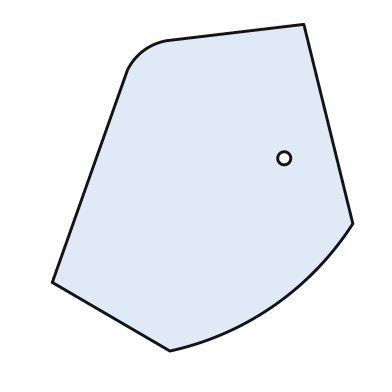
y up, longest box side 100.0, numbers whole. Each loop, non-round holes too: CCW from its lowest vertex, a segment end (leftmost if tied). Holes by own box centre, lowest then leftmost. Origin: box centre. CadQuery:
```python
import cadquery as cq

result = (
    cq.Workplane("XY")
    .moveTo(-10.0, -50.0)
    .threePointArc((22.0, -36.0), (46.0, -11.0))
    .lineTo(31.0, 50.0)
    .lineTo(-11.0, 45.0)
    .threePointArc((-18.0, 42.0), (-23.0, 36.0))
    .lineTo(-46.0, -29.0)
    .close()
    .moveTo(25.0, 9.0)
    .circle(2.0)
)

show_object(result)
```